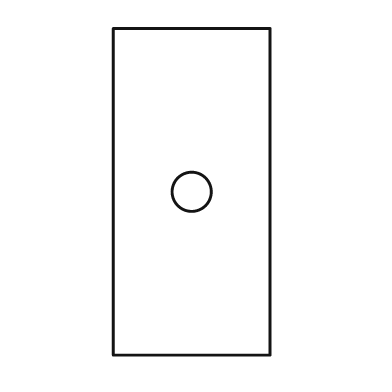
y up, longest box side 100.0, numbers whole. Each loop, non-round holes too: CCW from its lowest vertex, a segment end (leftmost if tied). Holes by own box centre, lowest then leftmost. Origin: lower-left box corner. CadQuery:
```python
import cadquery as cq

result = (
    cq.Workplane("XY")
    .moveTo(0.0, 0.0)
    .lineTo(48.0, 0.0)
    .lineTo(48.0, 100.0)
    .lineTo(0.0, 100.0)
    .close()
    .moveTo(24.0, 50.0)
    .circle(6.0)
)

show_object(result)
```